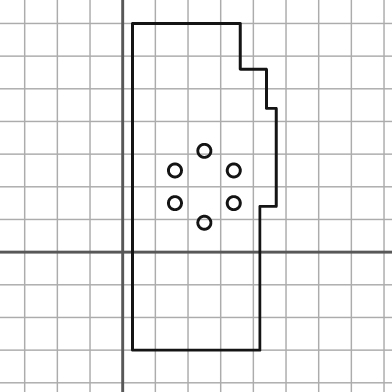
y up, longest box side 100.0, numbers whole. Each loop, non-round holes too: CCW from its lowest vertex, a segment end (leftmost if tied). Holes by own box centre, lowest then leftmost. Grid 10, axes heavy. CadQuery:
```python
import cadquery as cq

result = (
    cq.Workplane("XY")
    .moveTo(3.0, -30.0)
    .lineTo(42.0, -30.0)
    .lineTo(42.0, 14.0)
    .lineTo(47.0, 14.0)
    .lineTo(47.0, 44.0)
    .lineTo(44.0, 44.0)
    .lineTo(44.0, 56.0)
    .lineTo(36.0, 56.0)
    .lineTo(36.0, 70.0)
    .lineTo(3.0, 70.0)
    .close()
    .moveTo(25.0, 9.0)
    .circle(2.0)
    .moveTo(16.0, 15.0)
    .circle(2.0)
    .moveTo(34.0, 15.0)
    .circle(2.0)
    .moveTo(16.0, 25.0)
    .circle(2.0)
    .moveTo(34.0, 25.0)
    .circle(2.0)
    .moveTo(25.0, 31.0)
    .circle(2.0)
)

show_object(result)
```